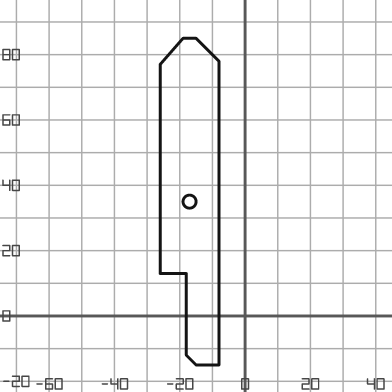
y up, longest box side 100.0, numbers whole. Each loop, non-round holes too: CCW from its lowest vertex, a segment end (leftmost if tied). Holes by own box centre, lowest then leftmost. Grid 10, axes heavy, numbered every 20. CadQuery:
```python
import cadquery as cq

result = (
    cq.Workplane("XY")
    .moveTo(-15.0, -15.0)
    .lineTo(-8.0, -15.0)
    .lineTo(-8.0, 78.0)
    .lineTo(-15.0, 85.0)
    .lineTo(-19.0, 85.0)
    .lineTo(-26.0, 77.0)
    .lineTo(-26.0, 13.0)
    .lineTo(-18.0, 13.0)
    .lineTo(-18.0, -12.0)
    .close()
    .moveTo(-17.0, 35.0)
    .circle(2.0)
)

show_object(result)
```